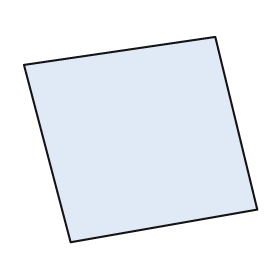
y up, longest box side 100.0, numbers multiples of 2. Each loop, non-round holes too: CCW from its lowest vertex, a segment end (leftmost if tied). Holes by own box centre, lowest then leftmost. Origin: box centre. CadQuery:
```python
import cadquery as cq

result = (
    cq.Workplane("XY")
    .moveTo(-30.0, -44.0)
    .lineTo(50.0, -30.0)
    .lineTo(32.0, 44.0)
    .lineTo(-50.0, 32.0)
    .close()
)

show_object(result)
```